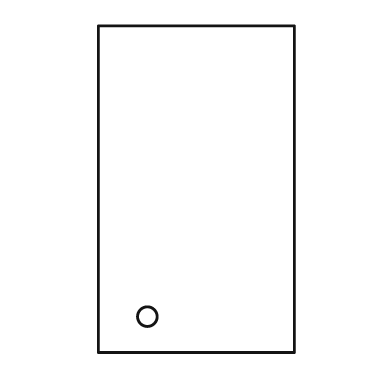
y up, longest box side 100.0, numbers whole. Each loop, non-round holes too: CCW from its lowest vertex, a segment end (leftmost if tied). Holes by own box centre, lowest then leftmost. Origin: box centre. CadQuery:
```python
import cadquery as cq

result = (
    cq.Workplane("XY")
    .moveTo(-30.0, -50.0)
    .lineTo(30.0, -50.0)
    .lineTo(30.0, 50.0)
    .lineTo(-30.0, 50.0)
    .close()
    .moveTo(-15.0, -39.0)
    .circle(3.0)
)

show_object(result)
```